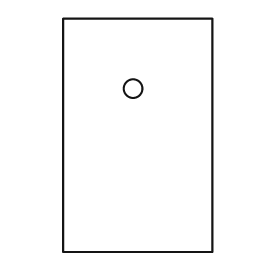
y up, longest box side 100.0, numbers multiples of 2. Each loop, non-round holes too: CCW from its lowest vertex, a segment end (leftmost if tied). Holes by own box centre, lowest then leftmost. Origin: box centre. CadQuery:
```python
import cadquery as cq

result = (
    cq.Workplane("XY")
    .moveTo(-32.0, -50.0)
    .lineTo(32.0, -50.0)
    .lineTo(32.0, 50.0)
    .lineTo(-32.0, 50.0)
    .close()
    .moveTo(-2.0, 20.0)
    .circle(4.0)
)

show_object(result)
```